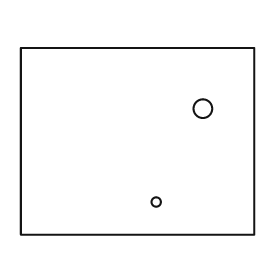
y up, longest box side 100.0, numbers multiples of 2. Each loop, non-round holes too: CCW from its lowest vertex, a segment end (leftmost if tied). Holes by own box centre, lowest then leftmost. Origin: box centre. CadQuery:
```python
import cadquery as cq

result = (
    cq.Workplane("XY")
    .moveTo(-50.0, -40.0)
    .lineTo(50.0, -40.0)
    .lineTo(50.0, 40.0)
    .lineTo(-50.0, 40.0)
    .close()
    .moveTo(8.0, -26.0)
    .circle(2.0)
    .moveTo(28.0, 14.0)
    .circle(4.0)
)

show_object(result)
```